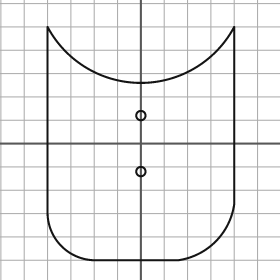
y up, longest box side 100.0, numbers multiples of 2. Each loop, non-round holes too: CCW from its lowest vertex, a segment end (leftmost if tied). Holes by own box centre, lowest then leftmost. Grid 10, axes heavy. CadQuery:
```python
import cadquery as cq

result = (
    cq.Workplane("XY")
    .moveTo(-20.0, -50.0)
    .lineTo(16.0, -50.0)
    .threePointArc((32.0, -42.0), (40.0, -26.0))
    .lineTo(40.0, 50.0)
    .threePointArc((0.0, 26.0), (-40.0, 50.0))
    .lineTo(-40.0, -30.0)
    .threePointArc((-34.0, -44.0), (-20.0, -50.0))
    .close()
    .moveTo(0.0, -12.0)
    .circle(2.0)
    .moveTo(0.0, 12.0)
    .circle(2.0)
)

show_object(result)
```